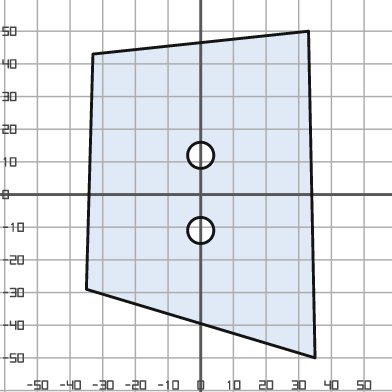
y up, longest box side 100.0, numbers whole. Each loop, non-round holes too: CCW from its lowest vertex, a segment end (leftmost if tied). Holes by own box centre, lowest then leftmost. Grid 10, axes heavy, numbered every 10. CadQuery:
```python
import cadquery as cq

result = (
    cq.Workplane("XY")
    .moveTo(35.0, -50.0)
    .lineTo(33.0, 50.0)
    .lineTo(-33.0, 43.0)
    .lineTo(-35.0, -29.0)
    .close()
    .moveTo(0.0, -11.0)
    .circle(4.0)
    .moveTo(0.0, 12.0)
    .circle(4.0)
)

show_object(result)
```